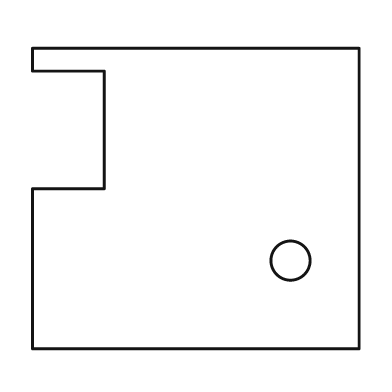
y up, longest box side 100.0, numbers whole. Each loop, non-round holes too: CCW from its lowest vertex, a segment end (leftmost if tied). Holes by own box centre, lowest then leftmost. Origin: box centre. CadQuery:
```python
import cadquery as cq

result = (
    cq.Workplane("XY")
    .moveTo(-50.0, -46.0)
    .lineTo(50.0, -46.0)
    .lineTo(50.0, 46.0)
    .lineTo(-50.0, 46.0)
    .lineTo(-50.0, 39.0)
    .lineTo(-28.0, 39.0)
    .lineTo(-28.0, 3.0)
    .lineTo(-50.0, 3.0)
    .close()
    .moveTo(29.0, -19.0)
    .circle(6.0)
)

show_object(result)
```